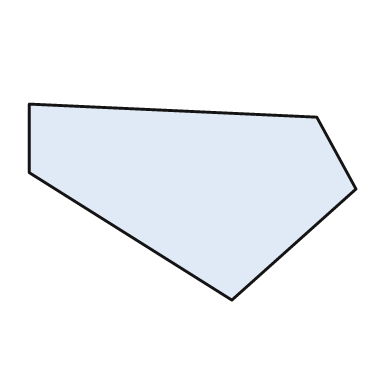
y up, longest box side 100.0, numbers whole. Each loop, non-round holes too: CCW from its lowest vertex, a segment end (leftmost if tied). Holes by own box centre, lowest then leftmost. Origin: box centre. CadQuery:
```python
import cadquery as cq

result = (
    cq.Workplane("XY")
    .moveTo(12.0, -30.0)
    .lineTo(50.0, 4.0)
    .lineTo(38.0, 26.0)
    .lineTo(-50.0, 30.0)
    .lineTo(-50.0, 9.0)
    .close()
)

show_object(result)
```